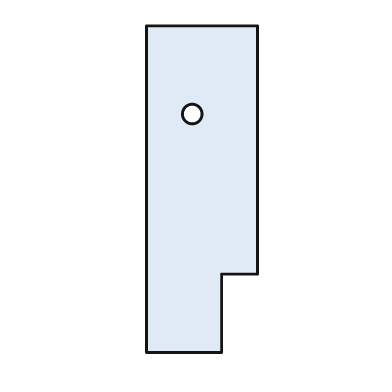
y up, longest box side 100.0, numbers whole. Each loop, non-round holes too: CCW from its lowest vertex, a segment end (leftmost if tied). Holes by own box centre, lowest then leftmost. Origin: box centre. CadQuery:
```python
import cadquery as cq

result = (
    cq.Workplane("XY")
    .moveTo(-17.0, -50.0)
    .lineTo(6.0, -50.0)
    .lineTo(6.0, -26.0)
    .lineTo(17.0, -26.0)
    .lineTo(17.0, 50.0)
    .lineTo(-17.0, 50.0)
    .close()
    .moveTo(-3.0, 23.0)
    .circle(3.0)
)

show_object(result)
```